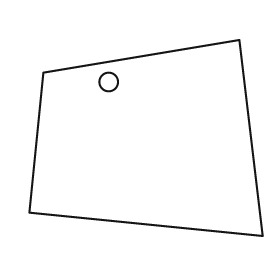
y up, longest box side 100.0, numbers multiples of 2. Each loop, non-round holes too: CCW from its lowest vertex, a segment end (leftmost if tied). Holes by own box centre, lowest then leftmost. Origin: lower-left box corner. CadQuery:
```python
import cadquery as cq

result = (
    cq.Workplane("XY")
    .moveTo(100.0, 0.0)
    .lineTo(90.0, 84.0)
    .lineTo(6.0, 70.0)
    .lineTo(0.0, 10.0)
    .close()
    .moveTo(34.0, 66.0)
    .circle(4.0)
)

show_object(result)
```